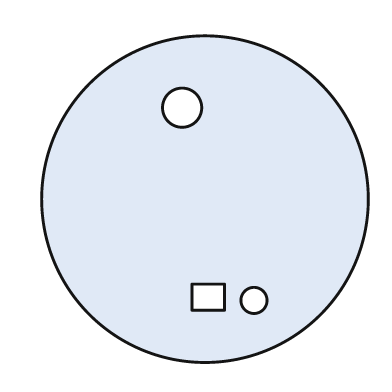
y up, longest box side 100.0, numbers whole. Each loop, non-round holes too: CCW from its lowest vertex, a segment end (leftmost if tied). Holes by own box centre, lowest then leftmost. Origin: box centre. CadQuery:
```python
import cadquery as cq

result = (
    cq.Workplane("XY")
    .moveTo(0.0, 0.0)
    .circle(50.0)
    .moveTo(15.0, -31.0)
    .circle(4.0)
    .moveTo(-4.0, -34.0)
    .lineTo(6.0, -34.0)
    .lineTo(6.0, -26.0)
    .lineTo(-4.0, -26.0)
    .close()
    .moveTo(-7.0, 28.0)
    .circle(6.0)
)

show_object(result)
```